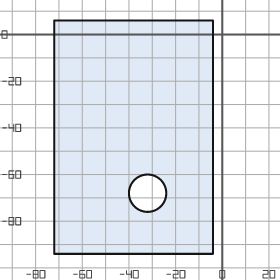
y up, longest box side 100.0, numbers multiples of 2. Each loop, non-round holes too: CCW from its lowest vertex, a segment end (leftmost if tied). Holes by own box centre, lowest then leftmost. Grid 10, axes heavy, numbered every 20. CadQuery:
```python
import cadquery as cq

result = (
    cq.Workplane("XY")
    .moveTo(-72.0, -94.0)
    .lineTo(-4.0, -94.0)
    .lineTo(-4.0, 6.0)
    .lineTo(-72.0, 6.0)
    .close()
    .moveTo(-32.0, -68.0)
    .circle(8.0)
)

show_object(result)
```